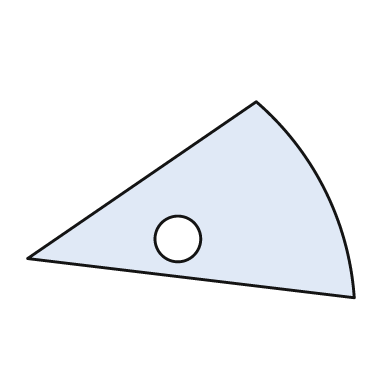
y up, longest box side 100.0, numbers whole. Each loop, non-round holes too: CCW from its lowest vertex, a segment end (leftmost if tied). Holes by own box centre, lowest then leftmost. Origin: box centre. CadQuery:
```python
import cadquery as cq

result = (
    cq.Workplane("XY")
    .moveTo(50.0, -30.0)
    .threePointArc((41.0, 3.0), (20.0, 30.0))
    .lineTo(-50.0, -18.0)
    .close()
    .moveTo(-4.0, -12.0)
    .circle(7.0)
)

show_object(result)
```